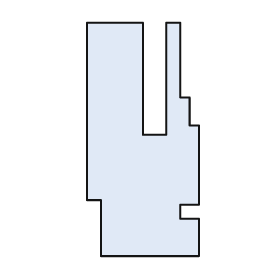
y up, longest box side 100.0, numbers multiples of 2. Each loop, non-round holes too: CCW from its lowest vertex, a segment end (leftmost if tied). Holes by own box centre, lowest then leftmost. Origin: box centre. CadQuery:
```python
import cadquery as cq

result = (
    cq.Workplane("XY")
    .moveTo(-18.0, -50.0)
    .lineTo(24.0, -50.0)
    .lineTo(24.0, -34.0)
    .lineTo(16.0, -34.0)
    .lineTo(16.0, -28.0)
    .lineTo(24.0, -28.0)
    .lineTo(24.0, 6.0)
    .lineTo(20.0, 6.0)
    .lineTo(20.0, 18.0)
    .lineTo(16.0, 18.0)
    .lineTo(16.0, 50.0)
    .lineTo(10.0, 50.0)
    .lineTo(10.0, 2.0)
    .lineTo(0.0, 2.0)
    .lineTo(0.0, 50.0)
    .lineTo(-24.0, 50.0)
    .lineTo(-24.0, -26.0)
    .lineTo(-18.0, -26.0)
    .close()
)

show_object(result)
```